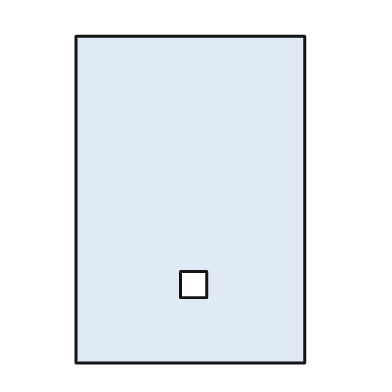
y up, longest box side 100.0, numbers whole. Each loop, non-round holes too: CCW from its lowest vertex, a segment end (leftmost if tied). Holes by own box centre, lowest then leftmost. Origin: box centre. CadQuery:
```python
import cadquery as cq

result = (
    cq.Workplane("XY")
    .moveTo(-35.0, -50.0)
    .lineTo(35.0, -50.0)
    .lineTo(35.0, 50.0)
    .lineTo(-35.0, 50.0)
    .close()
    .moveTo(-3.0, -30.0)
    .lineTo(5.0, -30.0)
    .lineTo(5.0, -22.0)
    .lineTo(-3.0, -22.0)
    .close()
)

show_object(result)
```